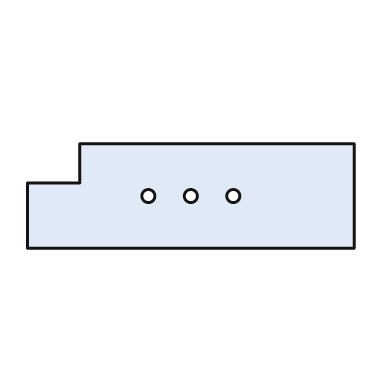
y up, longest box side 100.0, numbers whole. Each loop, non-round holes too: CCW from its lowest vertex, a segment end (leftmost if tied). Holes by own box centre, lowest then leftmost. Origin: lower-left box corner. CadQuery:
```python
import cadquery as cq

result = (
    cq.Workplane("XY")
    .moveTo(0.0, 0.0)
    .lineTo(100.0, 0.0)
    .lineTo(100.0, 32.0)
    .lineTo(16.0, 32.0)
    .lineTo(16.0, 20.0)
    .lineTo(0.0, 20.0)
    .close()
    .moveTo(37.0, 16.0)
    .circle(2.0)
    .moveTo(50.0, 16.0)
    .circle(2.0)
    .moveTo(63.0, 16.0)
    .circle(2.0)
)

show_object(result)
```